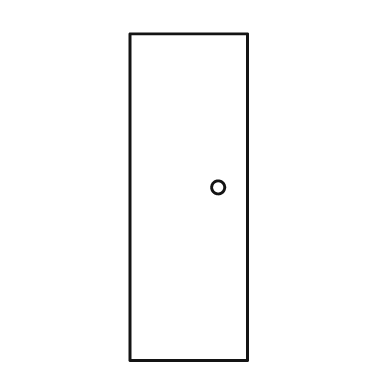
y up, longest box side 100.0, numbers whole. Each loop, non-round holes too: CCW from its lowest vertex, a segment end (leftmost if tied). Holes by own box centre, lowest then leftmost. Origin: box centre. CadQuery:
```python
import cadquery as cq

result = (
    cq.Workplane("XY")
    .moveTo(-18.0, -50.0)
    .lineTo(18.0, -50.0)
    .lineTo(18.0, 50.0)
    .lineTo(-18.0, 50.0)
    .close()
    .moveTo(9.0, 3.0)
    .circle(2.0)
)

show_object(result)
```